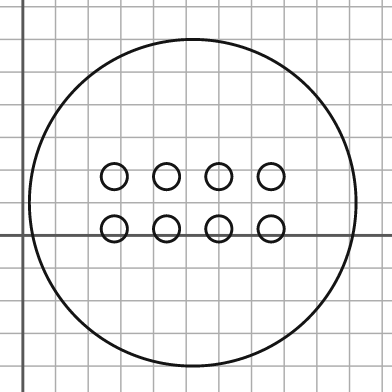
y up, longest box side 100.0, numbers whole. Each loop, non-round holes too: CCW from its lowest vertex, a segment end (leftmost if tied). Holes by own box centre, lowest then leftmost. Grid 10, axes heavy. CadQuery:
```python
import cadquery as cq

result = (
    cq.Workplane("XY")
    .moveTo(52.0, 10.0)
    .circle(50.0)
    .moveTo(28.0, 2.0)
    .circle(4.0)
    .moveTo(44.0, 2.0)
    .circle(4.0)
    .moveTo(60.0, 2.0)
    .circle(4.0)
    .moveTo(76.0, 2.0)
    .circle(4.0)
    .moveTo(28.0, 18.0)
    .circle(4.0)
    .moveTo(44.0, 18.0)
    .circle(4.0)
    .moveTo(60.0, 18.0)
    .circle(4.0)
    .moveTo(76.0, 18.0)
    .circle(4.0)
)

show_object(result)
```